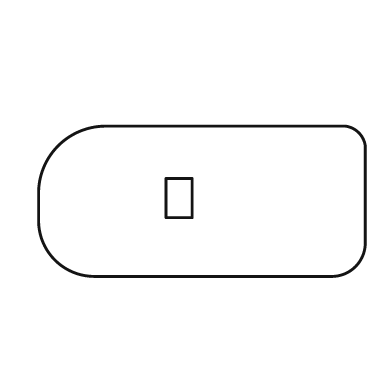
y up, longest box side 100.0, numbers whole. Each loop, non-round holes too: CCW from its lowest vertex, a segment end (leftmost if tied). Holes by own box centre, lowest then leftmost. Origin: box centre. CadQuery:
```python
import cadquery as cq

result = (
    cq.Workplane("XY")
    .moveTo(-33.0, -23.0)
    .lineTo(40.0, -23.0)
    .threePointArc((47.0, -20.0), (50.0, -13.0))
    .lineTo(50.0, 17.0)
    .threePointArc((48.0, 21.0), (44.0, 23.0))
    .lineTo(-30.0, 23.0)
    .threePointArc((-44.0, 17.0), (-50.0, 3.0))
    .lineTo(-50.0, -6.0)
    .threePointArc((-45.0, -18.0), (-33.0, -23.0))
    .close()
    .moveTo(-11.0, -5.0)
    .lineTo(-3.0, -5.0)
    .lineTo(-3.0, 7.0)
    .lineTo(-11.0, 7.0)
    .close()
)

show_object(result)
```